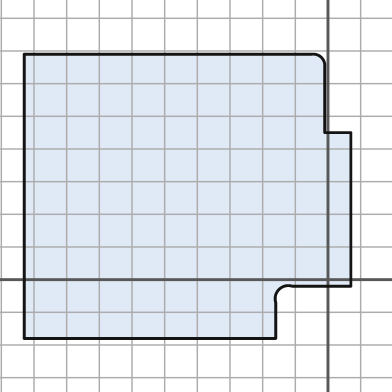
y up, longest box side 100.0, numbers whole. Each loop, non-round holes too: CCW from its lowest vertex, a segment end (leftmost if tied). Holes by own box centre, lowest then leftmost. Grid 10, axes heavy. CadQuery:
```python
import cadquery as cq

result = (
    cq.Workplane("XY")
    .moveTo(-93.0, -18.0)
    .lineTo(-16.0, -18.0)
    .lineTo(-16.0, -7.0)
    .threePointArc((-15.0, -3.0), (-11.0, -2.0))
    .lineTo(7.0, -2.0)
    .lineTo(7.0, 45.0)
    .lineTo(-1.0, 45.0)
    .lineTo(-1.0, 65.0)
    .threePointArc((-2.0, 68.0), (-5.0, 69.0))
    .lineTo(-93.0, 69.0)
    .close()
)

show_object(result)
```